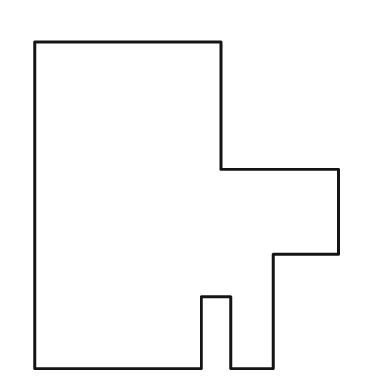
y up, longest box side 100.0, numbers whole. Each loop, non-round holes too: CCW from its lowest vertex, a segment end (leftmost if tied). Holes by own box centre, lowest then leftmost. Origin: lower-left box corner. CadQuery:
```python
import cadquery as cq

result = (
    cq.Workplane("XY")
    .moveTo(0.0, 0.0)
    .lineTo(51.0, 0.0)
    .lineTo(51.0, 22.0)
    .lineTo(60.0, 22.0)
    .lineTo(60.0, 0.0)
    .lineTo(73.0, 0.0)
    .lineTo(73.0, 35.0)
    .lineTo(93.0, 35.0)
    .lineTo(93.0, 61.0)
    .lineTo(57.0, 61.0)
    .lineTo(57.0, 100.0)
    .lineTo(0.0, 100.0)
    .close()
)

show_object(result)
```